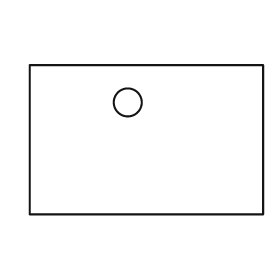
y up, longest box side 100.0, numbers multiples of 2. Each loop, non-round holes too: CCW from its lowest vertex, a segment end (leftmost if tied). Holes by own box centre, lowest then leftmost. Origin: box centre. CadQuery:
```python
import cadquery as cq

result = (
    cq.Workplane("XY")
    .moveTo(-50.0, -32.0)
    .lineTo(50.0, -32.0)
    .lineTo(50.0, 32.0)
    .lineTo(-50.0, 32.0)
    .close()
    .moveTo(-8.0, 16.0)
    .circle(6.0)
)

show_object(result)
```